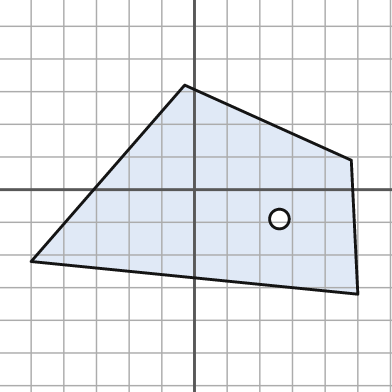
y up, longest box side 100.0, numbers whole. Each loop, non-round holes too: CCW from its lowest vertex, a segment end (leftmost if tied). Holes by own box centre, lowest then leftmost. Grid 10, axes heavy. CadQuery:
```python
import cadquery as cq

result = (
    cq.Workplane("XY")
    .moveTo(50.0, -32.0)
    .lineTo(48.0, 9.0)
    .lineTo(-3.0, 32.0)
    .lineTo(-50.0, -22.0)
    .close()
    .moveTo(26.0, -9.0)
    .circle(3.0)
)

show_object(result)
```